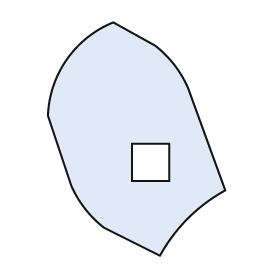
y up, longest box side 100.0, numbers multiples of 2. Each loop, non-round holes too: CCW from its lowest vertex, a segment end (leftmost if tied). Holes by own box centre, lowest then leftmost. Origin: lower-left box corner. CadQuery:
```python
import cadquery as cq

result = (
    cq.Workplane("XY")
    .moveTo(48.0, 0.0)
    .threePointArc((60.0, 16.0), (76.0, 28.0))
    .lineTo(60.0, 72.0)
    .threePointArc((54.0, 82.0), (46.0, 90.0))
    .lineTo(28.0, 100.0)
    .threePointArc((8.0, 84.0), (0.0, 60.0))
    .lineTo(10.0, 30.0)
    .threePointArc((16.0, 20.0), (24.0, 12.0))
    .close()
    .moveTo(36.0, 32.0)
    .lineTo(52.0, 32.0)
    .lineTo(52.0, 48.0)
    .lineTo(36.0, 48.0)
    .close()
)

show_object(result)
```